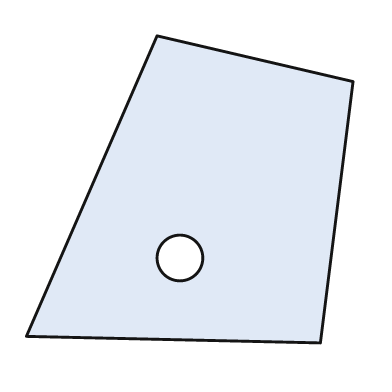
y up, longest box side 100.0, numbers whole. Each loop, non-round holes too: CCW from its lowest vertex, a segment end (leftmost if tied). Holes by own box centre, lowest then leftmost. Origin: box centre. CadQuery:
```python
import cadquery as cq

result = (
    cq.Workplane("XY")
    .moveTo(40.0, -47.0)
    .lineTo(50.0, 33.0)
    .lineTo(-10.0, 47.0)
    .lineTo(-50.0, -45.0)
    .close()
    .moveTo(-3.0, -21.0)
    .circle(7.0)
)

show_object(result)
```